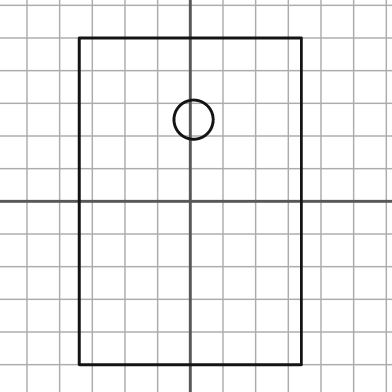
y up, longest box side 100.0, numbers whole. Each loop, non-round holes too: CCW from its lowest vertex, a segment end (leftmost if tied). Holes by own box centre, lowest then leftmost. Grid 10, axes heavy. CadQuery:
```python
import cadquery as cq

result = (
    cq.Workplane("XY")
    .moveTo(-34.0, -50.0)
    .lineTo(34.0, -50.0)
    .lineTo(34.0, 50.0)
    .lineTo(-34.0, 50.0)
    .close()
    .moveTo(1.0, 25.0)
    .circle(6.0)
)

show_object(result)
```